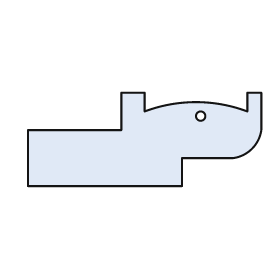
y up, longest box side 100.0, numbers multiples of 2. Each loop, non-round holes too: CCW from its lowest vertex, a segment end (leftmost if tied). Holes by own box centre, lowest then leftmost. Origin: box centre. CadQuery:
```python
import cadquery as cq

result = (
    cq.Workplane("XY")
    .moveTo(-50.0, -20.0)
    .lineTo(16.0, -20.0)
    .lineTo(16.0, -8.0)
    .lineTo(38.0, -8.0)
    .threePointArc((46.0, -4.0), (50.0, 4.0))
    .lineTo(50.0, 20.0)
    .lineTo(44.0, 20.0)
    .lineTo(44.0, 12.0)
    .threePointArc((22.0, 16.0), (0.0, 12.0))
    .lineTo(0.0, 20.0)
    .lineTo(-10.0, 20.0)
    .lineTo(-10.0, 4.0)
    .lineTo(-50.0, 4.0)
    .close()
    .moveTo(24.0, 10.0)
    .circle(2.0)
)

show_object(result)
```